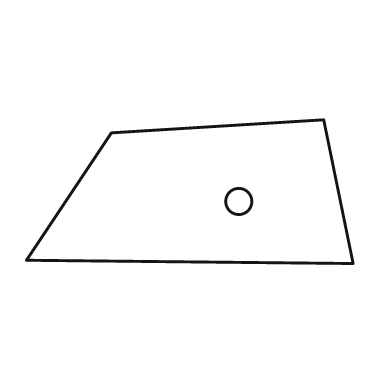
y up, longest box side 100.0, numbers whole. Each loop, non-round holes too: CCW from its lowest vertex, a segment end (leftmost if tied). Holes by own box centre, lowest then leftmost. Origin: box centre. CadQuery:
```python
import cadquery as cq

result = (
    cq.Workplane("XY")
    .moveTo(50.0, -22.0)
    .lineTo(41.0, 22.0)
    .lineTo(-24.0, 18.0)
    .lineTo(-50.0, -21.0)
    .close()
    .moveTo(15.0, -3.0)
    .circle(4.0)
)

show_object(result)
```